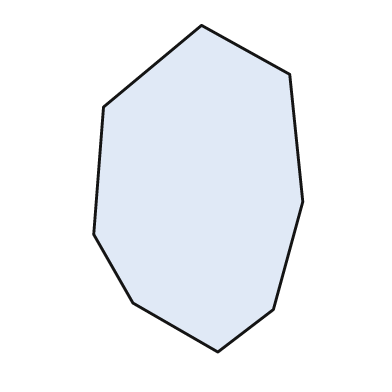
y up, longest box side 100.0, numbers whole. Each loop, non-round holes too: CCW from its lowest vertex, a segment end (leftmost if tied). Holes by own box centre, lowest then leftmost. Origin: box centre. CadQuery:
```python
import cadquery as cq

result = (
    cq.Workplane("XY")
    .moveTo(6.0, -50.0)
    .lineTo(23.0, -37.0)
    .lineTo(32.0, -4.0)
    .lineTo(28.0, 35.0)
    .lineTo(1.0, 50.0)
    .lineTo(-29.0, 25.0)
    .lineTo(-32.0, -14.0)
    .lineTo(-20.0, -35.0)
    .close()
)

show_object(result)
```